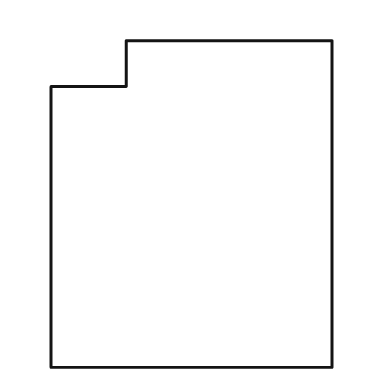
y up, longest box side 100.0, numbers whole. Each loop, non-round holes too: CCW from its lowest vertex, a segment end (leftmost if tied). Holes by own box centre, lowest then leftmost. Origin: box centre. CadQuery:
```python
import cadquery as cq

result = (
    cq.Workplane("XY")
    .moveTo(-43.0, -50.0)
    .lineTo(43.0, -50.0)
    .lineTo(43.0, 50.0)
    .lineTo(-20.0, 50.0)
    .lineTo(-20.0, 36.0)
    .lineTo(-43.0, 36.0)
    .close()
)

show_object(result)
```